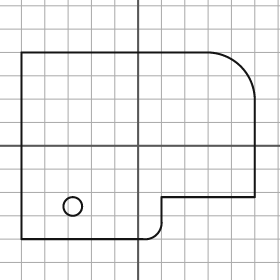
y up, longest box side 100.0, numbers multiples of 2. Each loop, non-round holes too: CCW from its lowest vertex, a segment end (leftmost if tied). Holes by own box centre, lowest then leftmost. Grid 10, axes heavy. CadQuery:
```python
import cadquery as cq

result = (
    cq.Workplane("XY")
    .moveTo(-50.0, -40.0)
    .lineTo(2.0, -40.0)
    .threePointArc((8.0, -38.0), (10.0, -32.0))
    .lineTo(10.0, -22.0)
    .lineTo(50.0, -22.0)
    .lineTo(50.0, 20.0)
    .threePointArc((44.0, 34.0), (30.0, 40.0))
    .lineTo(-50.0, 40.0)
    .close()
    .moveTo(-28.0, -26.0)
    .circle(4.0)
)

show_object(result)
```